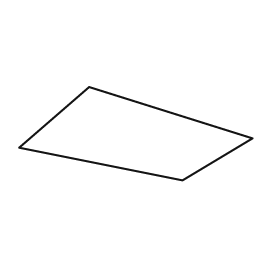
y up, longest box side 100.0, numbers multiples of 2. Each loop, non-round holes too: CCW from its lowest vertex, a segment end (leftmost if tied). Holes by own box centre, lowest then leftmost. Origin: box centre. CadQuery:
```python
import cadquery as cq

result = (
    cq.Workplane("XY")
    .moveTo(20.0, -20.0)
    .lineTo(50.0, -2.0)
    .lineTo(-20.0, 20.0)
    .lineTo(-50.0, -6.0)
    .close()
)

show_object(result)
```